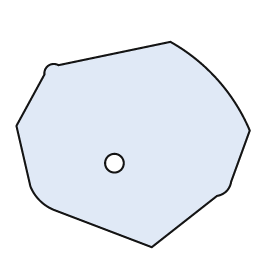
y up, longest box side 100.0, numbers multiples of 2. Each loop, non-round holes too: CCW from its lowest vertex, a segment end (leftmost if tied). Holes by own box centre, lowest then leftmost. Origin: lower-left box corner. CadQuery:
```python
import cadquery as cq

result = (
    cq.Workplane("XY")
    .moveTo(58.0, 0.0)
    .lineTo(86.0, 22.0)
    .threePointArc((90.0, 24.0), (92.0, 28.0))
    .lineTo(100.0, 50.0)
    .threePointArc((86.0, 72.0), (66.0, 88.0))
    .lineTo(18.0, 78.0)
    .threePointArc((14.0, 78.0), (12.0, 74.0))
    .lineTo(0.0, 52.0)
    .lineTo(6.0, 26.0)
    .threePointArc((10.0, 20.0), (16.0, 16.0))
    .close()
    .moveTo(42.0, 36.0)
    .circle(4.0)
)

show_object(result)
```